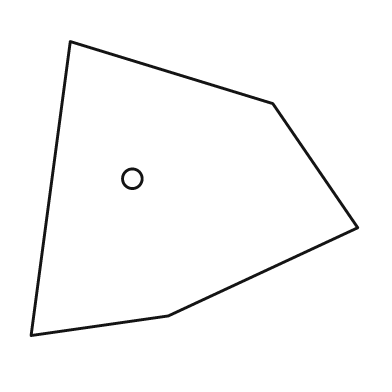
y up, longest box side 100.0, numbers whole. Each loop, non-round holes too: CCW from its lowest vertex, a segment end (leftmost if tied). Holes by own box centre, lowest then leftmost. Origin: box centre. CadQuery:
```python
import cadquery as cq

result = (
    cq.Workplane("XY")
    .moveTo(-50.0, -45.0)
    .lineTo(-8.0, -39.0)
    .lineTo(50.0, -12.0)
    .lineTo(24.0, 26.0)
    .lineTo(-38.0, 45.0)
    .close()
    .moveTo(-19.0, 3.0)
    .circle(3.0)
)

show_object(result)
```